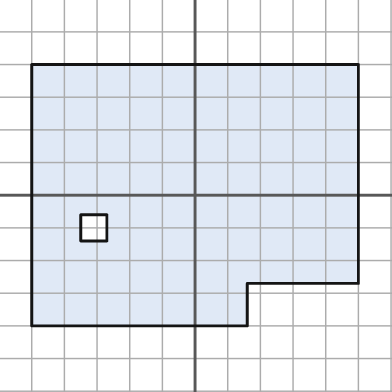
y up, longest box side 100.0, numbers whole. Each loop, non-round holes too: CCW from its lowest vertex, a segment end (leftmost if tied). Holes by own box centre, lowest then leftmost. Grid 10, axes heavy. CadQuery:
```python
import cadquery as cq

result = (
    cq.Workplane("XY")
    .moveTo(-50.0, -40.0)
    .lineTo(16.0, -40.0)
    .lineTo(16.0, -27.0)
    .lineTo(50.0, -27.0)
    .lineTo(50.0, 40.0)
    .lineTo(-50.0, 40.0)
    .close()
    .moveTo(-35.0, -14.0)
    .lineTo(-27.0, -14.0)
    .lineTo(-27.0, -6.0)
    .lineTo(-35.0, -6.0)
    .close()
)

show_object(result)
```